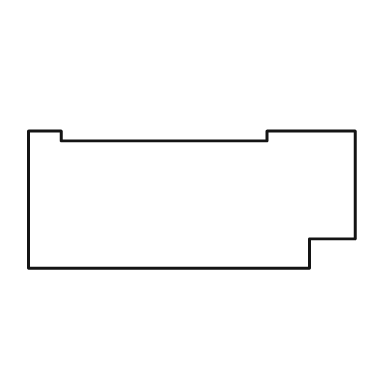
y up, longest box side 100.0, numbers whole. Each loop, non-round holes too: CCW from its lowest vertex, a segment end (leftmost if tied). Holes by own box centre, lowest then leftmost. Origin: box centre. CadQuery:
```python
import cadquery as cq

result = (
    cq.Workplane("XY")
    .moveTo(-50.0, -21.0)
    .lineTo(36.0, -21.0)
    .lineTo(36.0, -12.0)
    .lineTo(50.0, -12.0)
    .lineTo(50.0, 21.0)
    .lineTo(23.0, 21.0)
    .lineTo(23.0, 18.0)
    .lineTo(-40.0, 18.0)
    .lineTo(-40.0, 21.0)
    .lineTo(-50.0, 21.0)
    .close()
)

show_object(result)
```